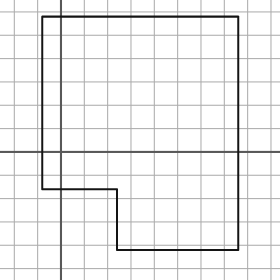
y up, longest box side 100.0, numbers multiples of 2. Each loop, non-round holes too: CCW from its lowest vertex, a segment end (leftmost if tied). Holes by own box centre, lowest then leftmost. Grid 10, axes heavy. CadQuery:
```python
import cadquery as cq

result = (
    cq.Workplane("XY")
    .moveTo(24.0, -42.0)
    .lineTo(76.0, -42.0)
    .lineTo(76.0, 58.0)
    .lineTo(-8.0, 58.0)
    .lineTo(-8.0, -16.0)
    .lineTo(24.0, -16.0)
    .close()
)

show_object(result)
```